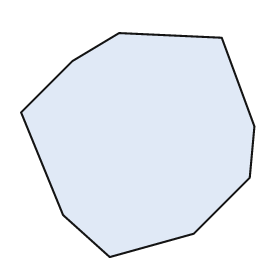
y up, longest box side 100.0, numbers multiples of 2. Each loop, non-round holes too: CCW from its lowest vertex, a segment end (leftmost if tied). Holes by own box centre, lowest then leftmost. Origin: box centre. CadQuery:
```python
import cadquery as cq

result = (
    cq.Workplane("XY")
    .moveTo(-12.0, -48.0)
    .lineTo(24.0, -38.0)
    .lineTo(48.0, -14.0)
    .lineTo(50.0, 8.0)
    .lineTo(36.0, 46.0)
    .lineTo(-8.0, 48.0)
    .lineTo(-28.0, 36.0)
    .lineTo(-50.0, 14.0)
    .lineTo(-32.0, -30.0)
    .close()
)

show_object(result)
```